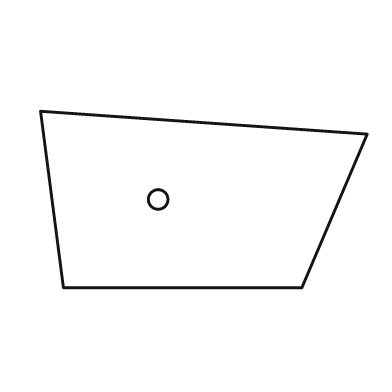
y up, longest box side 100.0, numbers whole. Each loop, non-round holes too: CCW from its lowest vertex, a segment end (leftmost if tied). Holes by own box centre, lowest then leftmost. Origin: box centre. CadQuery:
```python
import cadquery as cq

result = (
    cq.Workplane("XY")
    .moveTo(-43.0, -27.0)
    .lineTo(30.0, -27.0)
    .lineTo(50.0, 20.0)
    .lineTo(-50.0, 27.0)
    .close()
    .moveTo(-14.0, 0.0)
    .circle(3.0)
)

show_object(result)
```